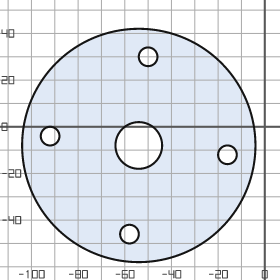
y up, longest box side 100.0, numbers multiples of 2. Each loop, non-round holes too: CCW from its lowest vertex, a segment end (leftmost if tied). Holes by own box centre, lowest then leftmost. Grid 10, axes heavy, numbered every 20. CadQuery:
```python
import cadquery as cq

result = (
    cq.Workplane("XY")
    .moveTo(-54.0, -8.0)
    .circle(50.0)
    .moveTo(-58.0, -46.0)
    .circle(4.0)
    .moveTo(-16.0, -12.0)
    .circle(4.0)
    .moveTo(-54.0, -8.0)
    .circle(10.0)
    .moveTo(-92.0, -4.0)
    .circle(4.0)
    .moveTo(-50.0, 30.0)
    .circle(4.0)
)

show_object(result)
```